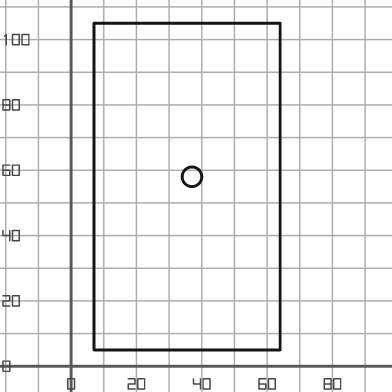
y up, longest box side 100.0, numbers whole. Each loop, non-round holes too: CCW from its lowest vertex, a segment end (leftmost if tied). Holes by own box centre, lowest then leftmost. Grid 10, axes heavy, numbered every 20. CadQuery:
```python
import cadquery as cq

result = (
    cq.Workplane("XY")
    .moveTo(7.0, 5.0)
    .lineTo(64.0, 5.0)
    .lineTo(64.0, 105.0)
    .lineTo(7.0, 105.0)
    .close()
    .moveTo(37.0, 58.0)
    .circle(3.0)
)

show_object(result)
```